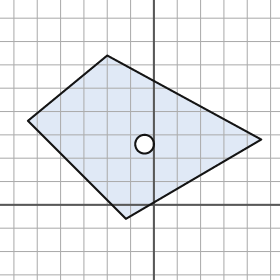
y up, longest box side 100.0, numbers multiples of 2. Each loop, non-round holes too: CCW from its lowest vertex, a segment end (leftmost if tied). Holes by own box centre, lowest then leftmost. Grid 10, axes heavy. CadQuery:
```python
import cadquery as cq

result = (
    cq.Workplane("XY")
    .moveTo(-12.0, -6.0)
    .lineTo(46.0, 28.0)
    .lineTo(-20.0, 64.0)
    .lineTo(-54.0, 36.0)
    .close()
    .moveTo(-4.0, 26.0)
    .circle(4.0)
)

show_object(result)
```